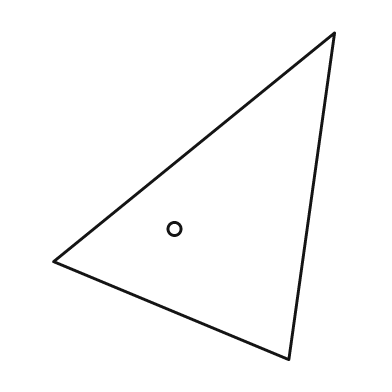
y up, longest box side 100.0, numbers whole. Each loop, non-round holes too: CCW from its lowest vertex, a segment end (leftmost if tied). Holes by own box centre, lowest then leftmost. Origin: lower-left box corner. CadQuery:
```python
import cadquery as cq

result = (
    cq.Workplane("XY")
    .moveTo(72.0, 0.0)
    .lineTo(86.0, 100.0)
    .lineTo(0.0, 30.0)
    .close()
    .moveTo(37.0, 40.0)
    .circle(2.0)
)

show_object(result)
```